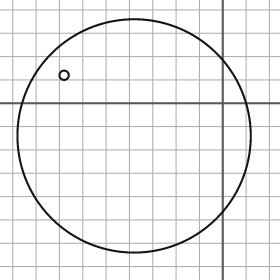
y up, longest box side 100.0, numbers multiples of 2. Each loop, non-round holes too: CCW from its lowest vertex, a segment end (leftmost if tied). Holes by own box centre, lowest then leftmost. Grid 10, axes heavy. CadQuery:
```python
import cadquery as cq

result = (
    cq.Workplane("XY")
    .moveTo(-38.0, -14.0)
    .circle(50.0)
    .moveTo(-68.0, 12.0)
    .circle(2.0)
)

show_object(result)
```